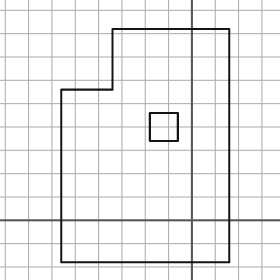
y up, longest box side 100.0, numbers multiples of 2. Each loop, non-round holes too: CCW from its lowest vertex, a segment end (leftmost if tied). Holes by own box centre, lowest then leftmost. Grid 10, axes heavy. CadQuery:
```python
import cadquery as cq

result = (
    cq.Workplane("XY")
    .moveTo(-56.0, -18.0)
    .lineTo(16.0, -18.0)
    .lineTo(16.0, 82.0)
    .lineTo(-34.0, 82.0)
    .lineTo(-34.0, 56.0)
    .lineTo(-56.0, 56.0)
    .close()
    .moveTo(-18.0, 34.0)
    .lineTo(-6.0, 34.0)
    .lineTo(-6.0, 46.0)
    .lineTo(-18.0, 46.0)
    .close()
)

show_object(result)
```